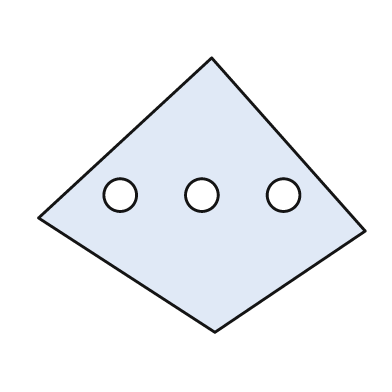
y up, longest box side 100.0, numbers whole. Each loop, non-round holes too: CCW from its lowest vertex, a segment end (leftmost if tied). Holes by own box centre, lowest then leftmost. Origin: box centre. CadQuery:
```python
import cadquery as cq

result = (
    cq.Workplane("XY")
    .moveTo(4.0, -42.0)
    .lineTo(50.0, -11.0)
    .lineTo(3.0, 42.0)
    .lineTo(-50.0, -7.0)
    .close()
    .moveTo(-25.0, 0.0)
    .circle(5.0)
    .moveTo(0.0, 0.0)
    .circle(5.0)
    .moveTo(25.0, 0.0)
    .circle(5.0)
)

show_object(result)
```